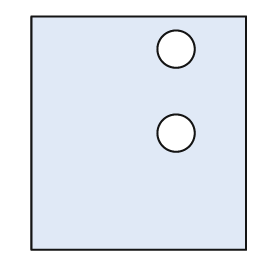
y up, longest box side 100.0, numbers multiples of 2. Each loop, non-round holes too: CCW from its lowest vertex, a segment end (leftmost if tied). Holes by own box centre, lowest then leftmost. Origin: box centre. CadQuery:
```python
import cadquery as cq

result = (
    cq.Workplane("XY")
    .moveTo(-46.0, -50.0)
    .lineTo(46.0, -50.0)
    .lineTo(46.0, 50.0)
    .lineTo(-46.0, 50.0)
    .close()
    .moveTo(16.0, 0.0)
    .circle(8.0)
    .moveTo(16.0, 36.0)
    .circle(8.0)
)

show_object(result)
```